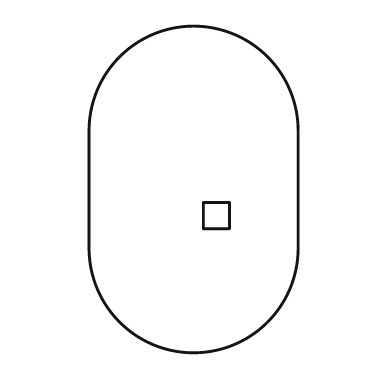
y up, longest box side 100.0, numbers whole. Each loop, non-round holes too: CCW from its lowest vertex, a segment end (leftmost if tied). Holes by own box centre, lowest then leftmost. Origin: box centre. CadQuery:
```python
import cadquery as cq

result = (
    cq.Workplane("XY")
    .moveTo(-32.0, -18.0)
    .threePointArc((0.0, -50.0), (32.0, -18.0))
    .lineTo(32.0, 18.0)
    .threePointArc((0.0, 50.0), (-32.0, 18.0))
    .close()
    .moveTo(3.0, -12.0)
    .lineTo(11.0, -12.0)
    .lineTo(11.0, -4.0)
    .lineTo(3.0, -4.0)
    .close()
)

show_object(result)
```